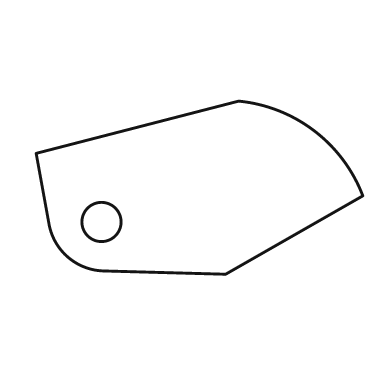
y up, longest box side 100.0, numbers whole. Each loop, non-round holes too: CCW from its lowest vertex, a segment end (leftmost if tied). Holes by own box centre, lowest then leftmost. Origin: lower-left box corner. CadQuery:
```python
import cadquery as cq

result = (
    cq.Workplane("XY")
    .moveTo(58.0, 0.0)
    .lineTo(100.0, 24.0)
    .threePointArc((85.0, 44.0), (62.0, 53.0))
    .lineTo(0.0, 37.0)
    .lineTo(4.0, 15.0)
    .threePointArc((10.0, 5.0), (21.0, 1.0))
    .close()
    .moveTo(20.0, 16.0)
    .circle(6.0)
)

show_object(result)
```